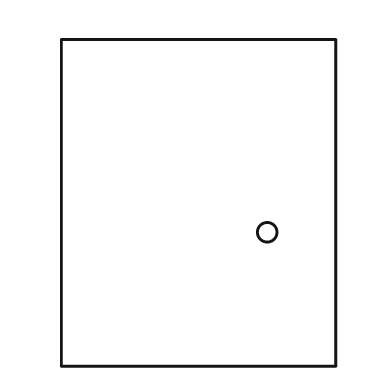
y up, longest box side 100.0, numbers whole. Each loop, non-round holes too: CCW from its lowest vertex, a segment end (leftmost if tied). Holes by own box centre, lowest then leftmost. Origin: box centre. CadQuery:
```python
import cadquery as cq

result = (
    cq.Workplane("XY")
    .moveTo(-42.0, -50.0)
    .lineTo(42.0, -50.0)
    .lineTo(42.0, 50.0)
    .lineTo(-42.0, 50.0)
    .close()
    .moveTo(21.0, -9.0)
    .circle(3.0)
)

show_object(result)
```